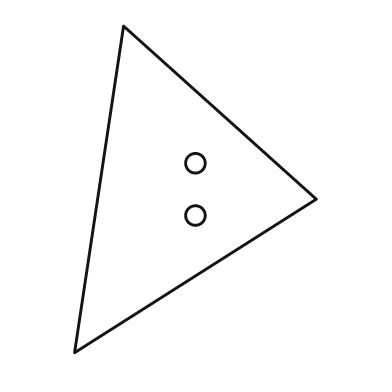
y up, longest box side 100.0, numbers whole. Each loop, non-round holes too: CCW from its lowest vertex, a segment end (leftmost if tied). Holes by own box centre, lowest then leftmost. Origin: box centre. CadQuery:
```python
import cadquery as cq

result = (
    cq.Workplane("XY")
    .moveTo(-37.0, -50.0)
    .lineTo(37.0, -3.0)
    .lineTo(-22.0, 50.0)
    .close()
    .moveTo(0.0, -8.0)
    .circle(3.0)
    .moveTo(0.0, 8.0)
    .circle(3.0)
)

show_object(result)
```